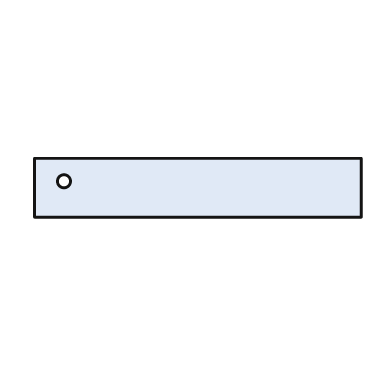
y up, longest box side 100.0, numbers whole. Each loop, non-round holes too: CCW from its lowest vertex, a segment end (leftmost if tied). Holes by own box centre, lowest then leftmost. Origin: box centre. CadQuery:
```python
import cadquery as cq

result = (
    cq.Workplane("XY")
    .moveTo(-50.0, -9.0)
    .lineTo(50.0, -9.0)
    .lineTo(50.0, 9.0)
    .lineTo(-50.0, 9.0)
    .close()
    .moveTo(-41.0, 2.0)
    .circle(2.0)
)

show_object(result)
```